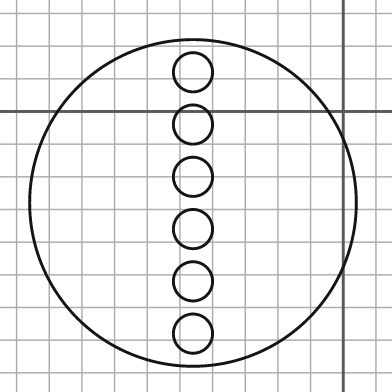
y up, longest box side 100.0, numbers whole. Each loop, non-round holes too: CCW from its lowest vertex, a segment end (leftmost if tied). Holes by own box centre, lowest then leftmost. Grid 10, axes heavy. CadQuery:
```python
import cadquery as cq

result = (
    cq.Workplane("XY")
    .moveTo(-46.0, -28.0)
    .circle(50.0)
    .moveTo(-46.0, -68.0)
    .circle(6.0)
    .moveTo(-46.0, -52.0)
    .circle(6.0)
    .moveTo(-46.0, -36.0)
    .circle(6.0)
    .moveTo(-46.0, -20.0)
    .circle(6.0)
    .moveTo(-46.0, -4.0)
    .circle(6.0)
    .moveTo(-46.0, 12.0)
    .circle(6.0)
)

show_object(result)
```